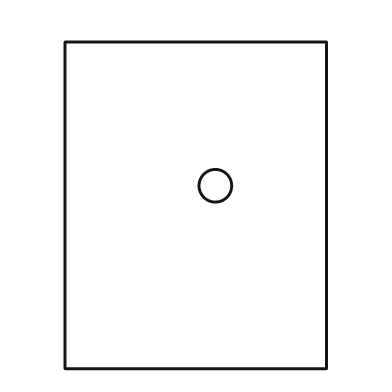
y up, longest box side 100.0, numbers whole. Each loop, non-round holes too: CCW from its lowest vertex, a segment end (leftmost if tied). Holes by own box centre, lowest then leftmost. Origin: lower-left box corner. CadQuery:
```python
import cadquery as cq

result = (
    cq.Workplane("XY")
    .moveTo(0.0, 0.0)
    .lineTo(80.0, 0.0)
    .lineTo(80.0, 100.0)
    .lineTo(0.0, 100.0)
    .close()
    .moveTo(46.0, 56.0)
    .circle(5.0)
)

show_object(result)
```